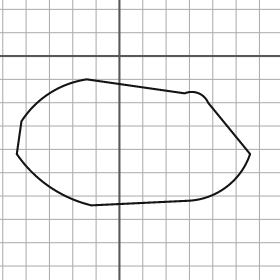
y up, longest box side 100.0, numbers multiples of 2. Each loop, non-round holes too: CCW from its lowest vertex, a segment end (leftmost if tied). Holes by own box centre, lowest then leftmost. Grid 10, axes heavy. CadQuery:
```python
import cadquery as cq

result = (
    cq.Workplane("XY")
    .moveTo(-12.0, -64.0)
    .lineTo(30.0, -62.0)
    .threePointArc((46.0, -56.0), (56.0, -42.0))
    .lineTo(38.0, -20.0)
    .threePointArc((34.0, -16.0), (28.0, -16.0))
    .lineTo(-14.0, -10.0)
    .threePointArc((-30.0, -16.0), (-42.0, -28.0))
    .lineTo(-44.0, -42.0)
    .threePointArc((-30.0, -56.0), (-12.0, -64.0))
    .close()
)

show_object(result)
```